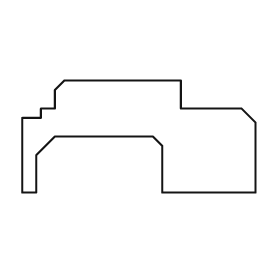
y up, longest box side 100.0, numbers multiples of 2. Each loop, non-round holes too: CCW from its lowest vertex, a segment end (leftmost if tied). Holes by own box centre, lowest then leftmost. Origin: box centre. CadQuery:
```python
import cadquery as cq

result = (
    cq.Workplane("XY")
    .moveTo(-50.0, -24.0)
    .lineTo(-44.0, -24.0)
    .lineTo(-44.0, -8.0)
    .lineTo(-36.0, 0.0)
    .lineTo(6.0, 0.0)
    .lineTo(10.0, -4.0)
    .lineTo(10.0, -24.0)
    .lineTo(50.0, -24.0)
    .lineTo(50.0, 6.0)
    .lineTo(44.0, 12.0)
    .lineTo(18.0, 12.0)
    .lineTo(18.0, 24.0)
    .lineTo(-32.0, 24.0)
    .lineTo(-36.0, 20.0)
    .lineTo(-36.0, 12.0)
    .lineTo(-42.0, 12.0)
    .lineTo(-42.0, 8.0)
    .lineTo(-50.0, 8.0)
    .close()
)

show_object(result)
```